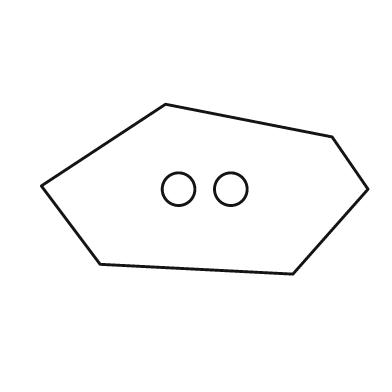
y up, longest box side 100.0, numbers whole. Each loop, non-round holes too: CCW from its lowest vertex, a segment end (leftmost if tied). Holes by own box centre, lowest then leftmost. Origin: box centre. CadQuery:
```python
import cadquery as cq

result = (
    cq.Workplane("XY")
    .moveTo(27.0, -26.0)
    .lineTo(50.0, 0.0)
    .lineTo(39.0, 16.0)
    .lineTo(-12.0, 26.0)
    .lineTo(-50.0, 1.0)
    .lineTo(-32.0, -23.0)
    .close()
    .moveTo(-8.0, 0.0)
    .circle(5.0)
    .moveTo(8.0, 0.0)
    .circle(5.0)
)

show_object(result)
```